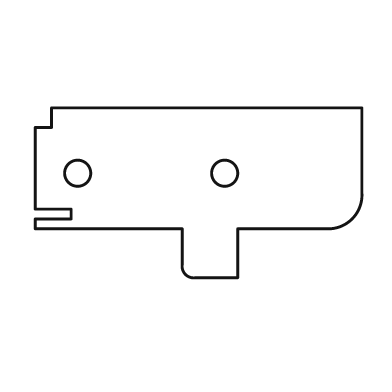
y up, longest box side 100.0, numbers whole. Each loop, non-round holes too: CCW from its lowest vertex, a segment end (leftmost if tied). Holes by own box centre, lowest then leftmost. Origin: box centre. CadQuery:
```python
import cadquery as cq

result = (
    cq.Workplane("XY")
    .moveTo(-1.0, -26.0)
    .lineTo(12.0, -26.0)
    .lineTo(12.0, -11.0)
    .lineTo(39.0, -11.0)
    .threePointArc((47.0, -8.0), (50.0, 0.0))
    .lineTo(50.0, 26.0)
    .lineTo(-45.0, 26.0)
    .lineTo(-45.0, 20.0)
    .lineTo(-50.0, 20.0)
    .lineTo(-50.0, -5.0)
    .lineTo(-39.0, -5.0)
    .lineTo(-39.0, -8.0)
    .lineTo(-50.0, -8.0)
    .lineTo(-50.0, -11.0)
    .lineTo(-5.0, -11.0)
    .lineTo(-5.0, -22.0)
    .threePointArc((-4.0, -25.0), (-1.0, -26.0))
    .close()
    .moveTo(-37.0, 6.0)
    .circle(4.0)
    .moveTo(8.0, 6.0)
    .circle(4.0)
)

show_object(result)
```